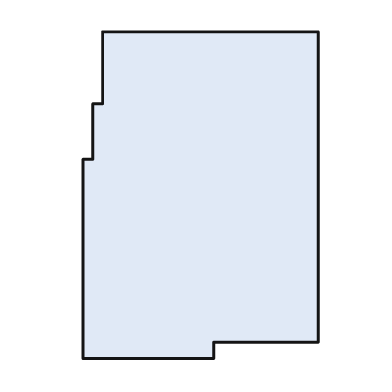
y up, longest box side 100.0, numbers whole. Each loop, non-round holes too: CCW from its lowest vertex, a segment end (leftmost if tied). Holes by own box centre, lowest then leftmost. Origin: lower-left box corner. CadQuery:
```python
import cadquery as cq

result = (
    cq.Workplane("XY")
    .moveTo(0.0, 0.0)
    .lineTo(40.0, 0.0)
    .lineTo(40.0, 5.0)
    .lineTo(72.0, 5.0)
    .lineTo(72.0, 100.0)
    .lineTo(6.0, 100.0)
    .lineTo(6.0, 78.0)
    .lineTo(3.0, 78.0)
    .lineTo(3.0, 61.0)
    .lineTo(0.0, 61.0)
    .close()
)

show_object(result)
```